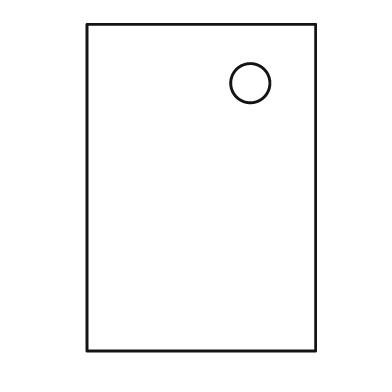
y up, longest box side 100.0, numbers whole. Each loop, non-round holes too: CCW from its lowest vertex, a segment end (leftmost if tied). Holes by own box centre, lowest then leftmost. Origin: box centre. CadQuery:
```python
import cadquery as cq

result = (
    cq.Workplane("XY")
    .moveTo(-35.0, -50.0)
    .lineTo(35.0, -50.0)
    .lineTo(35.0, 50.0)
    .lineTo(-35.0, 50.0)
    .close()
    .moveTo(15.0, 32.0)
    .circle(6.0)
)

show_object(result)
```